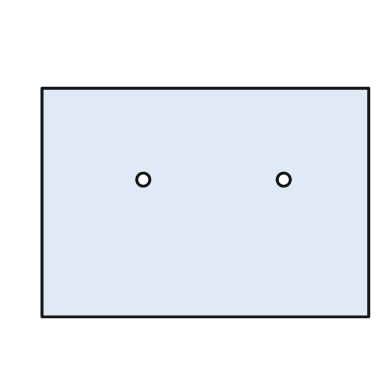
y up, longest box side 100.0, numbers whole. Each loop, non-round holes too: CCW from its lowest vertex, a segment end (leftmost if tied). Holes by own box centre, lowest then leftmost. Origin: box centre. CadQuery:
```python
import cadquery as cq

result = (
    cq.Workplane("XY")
    .moveTo(-50.0, -35.0)
    .lineTo(50.0, -35.0)
    .lineTo(50.0, 35.0)
    .lineTo(-50.0, 35.0)
    .close()
    .moveTo(-19.0, 7.0)
    .circle(2.0)
    .moveTo(24.0, 7.0)
    .circle(2.0)
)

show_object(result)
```